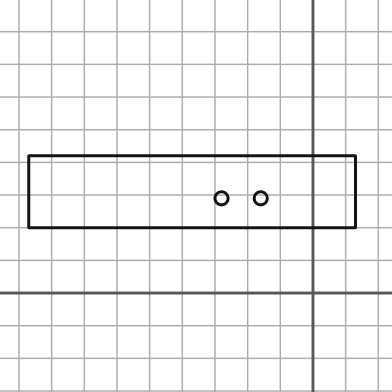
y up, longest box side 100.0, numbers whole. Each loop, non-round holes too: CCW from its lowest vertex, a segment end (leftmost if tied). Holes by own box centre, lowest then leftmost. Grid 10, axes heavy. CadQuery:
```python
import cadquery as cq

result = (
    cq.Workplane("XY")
    .moveTo(-87.0, 20.0)
    .lineTo(13.0, 20.0)
    .lineTo(13.0, 42.0)
    .lineTo(-87.0, 42.0)
    .close()
    .moveTo(-28.0, 29.0)
    .circle(2.0)
    .moveTo(-16.0, 29.0)
    .circle(2.0)
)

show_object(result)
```